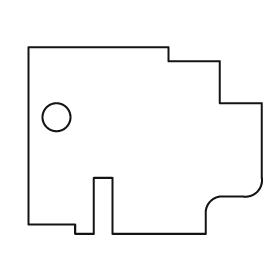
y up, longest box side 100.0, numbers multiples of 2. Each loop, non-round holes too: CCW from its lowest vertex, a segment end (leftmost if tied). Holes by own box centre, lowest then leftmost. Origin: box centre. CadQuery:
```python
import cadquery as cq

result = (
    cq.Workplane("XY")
    .moveTo(-30.0, -40.0)
    .lineTo(-22.0, -40.0)
    .lineTo(-22.0, -16.0)
    .lineTo(-14.0, -16.0)
    .lineTo(-14.0, -40.0)
    .lineTo(26.0, -40.0)
    .lineTo(26.0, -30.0)
    .threePointArc((28.0, -26.0), (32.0, -24.0))
    .lineTo(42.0, -24.0)
    .threePointArc((48.0, -22.0), (50.0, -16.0))
    .lineTo(50.0, 16.0)
    .lineTo(32.0, 16.0)
    .lineTo(32.0, 34.0)
    .lineTo(10.0, 34.0)
    .lineTo(10.0, 40.0)
    .lineTo(-50.0, 40.0)
    .lineTo(-50.0, -36.0)
    .lineTo(-30.0, -36.0)
    .close()
    .moveTo(-38.0, 10.0)
    .circle(6.0)
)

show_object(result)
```